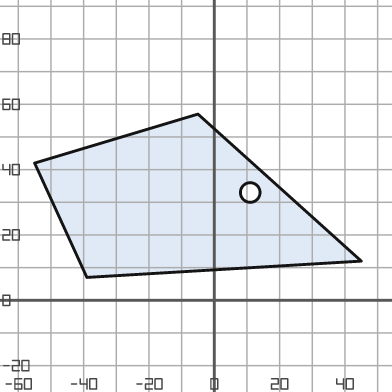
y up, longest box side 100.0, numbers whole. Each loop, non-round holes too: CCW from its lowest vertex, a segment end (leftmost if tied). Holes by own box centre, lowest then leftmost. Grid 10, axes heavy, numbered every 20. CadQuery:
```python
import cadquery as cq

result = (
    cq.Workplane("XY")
    .moveTo(-39.0, 7.0)
    .lineTo(45.0, 12.0)
    .lineTo(-5.0, 57.0)
    .lineTo(-55.0, 42.0)
    .close()
    .moveTo(11.0, 33.0)
    .circle(3.0)
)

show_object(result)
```